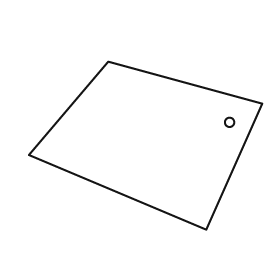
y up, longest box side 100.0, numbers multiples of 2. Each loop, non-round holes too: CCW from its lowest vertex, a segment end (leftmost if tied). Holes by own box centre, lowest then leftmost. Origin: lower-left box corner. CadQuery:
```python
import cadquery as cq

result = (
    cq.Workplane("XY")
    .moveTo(76.0, 0.0)
    .lineTo(100.0, 54.0)
    .lineTo(34.0, 72.0)
    .lineTo(0.0, 32.0)
    .close()
    .moveTo(86.0, 46.0)
    .circle(2.0)
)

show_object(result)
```